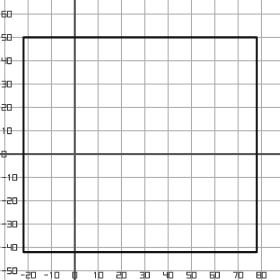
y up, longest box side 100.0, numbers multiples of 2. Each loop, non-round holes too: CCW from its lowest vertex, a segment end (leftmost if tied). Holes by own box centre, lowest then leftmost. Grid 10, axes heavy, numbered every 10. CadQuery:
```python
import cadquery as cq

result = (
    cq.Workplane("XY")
    .moveTo(-22.0, -42.0)
    .lineTo(78.0, -42.0)
    .lineTo(78.0, 50.0)
    .lineTo(-22.0, 50.0)
    .close()
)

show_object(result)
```